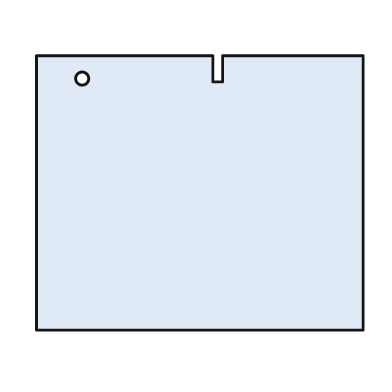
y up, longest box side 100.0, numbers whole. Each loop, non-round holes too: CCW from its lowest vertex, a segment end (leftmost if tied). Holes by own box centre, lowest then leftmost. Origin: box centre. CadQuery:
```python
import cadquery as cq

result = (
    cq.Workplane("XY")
    .moveTo(-50.0, -42.0)
    .lineTo(50.0, -42.0)
    .lineTo(50.0, 42.0)
    .lineTo(7.0, 42.0)
    .lineTo(7.0, 34.0)
    .lineTo(4.0, 34.0)
    .lineTo(4.0, 42.0)
    .lineTo(-50.0, 42.0)
    .close()
    .moveTo(-36.0, 35.0)
    .circle(2.0)
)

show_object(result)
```